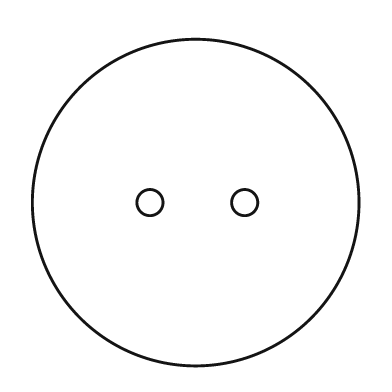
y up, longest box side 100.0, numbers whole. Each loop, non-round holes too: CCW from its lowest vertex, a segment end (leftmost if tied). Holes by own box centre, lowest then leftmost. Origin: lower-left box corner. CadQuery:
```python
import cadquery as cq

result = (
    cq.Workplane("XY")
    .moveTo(50.0, 50.0)
    .circle(50.0)
    .moveTo(36.0, 50.0)
    .circle(4.0)
    .moveTo(65.0, 50.0)
    .circle(4.0)
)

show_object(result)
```